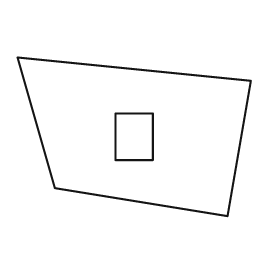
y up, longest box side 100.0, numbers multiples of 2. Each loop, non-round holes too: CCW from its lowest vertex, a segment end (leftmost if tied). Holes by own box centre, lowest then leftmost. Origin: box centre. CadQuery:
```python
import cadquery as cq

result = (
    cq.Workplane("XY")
    .moveTo(40.0, -34.0)
    .lineTo(50.0, 24.0)
    .lineTo(-50.0, 34.0)
    .lineTo(-34.0, -22.0)
    .close()
    .moveTo(-8.0, -10.0)
    .lineTo(8.0, -10.0)
    .lineTo(8.0, 10.0)
    .lineTo(-8.0, 10.0)
    .close()
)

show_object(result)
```